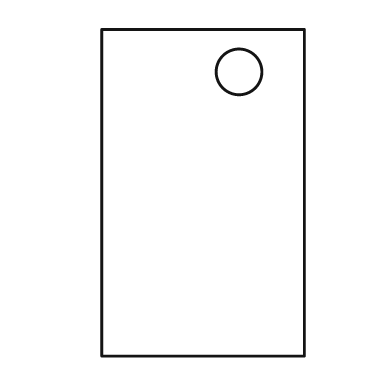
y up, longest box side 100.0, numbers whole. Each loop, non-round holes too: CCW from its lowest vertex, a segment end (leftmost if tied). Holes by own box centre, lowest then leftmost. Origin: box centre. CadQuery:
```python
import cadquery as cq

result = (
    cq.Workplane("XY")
    .moveTo(-31.0, -50.0)
    .lineTo(31.0, -50.0)
    .lineTo(31.0, 50.0)
    .lineTo(-31.0, 50.0)
    .close()
    .moveTo(11.0, 37.0)
    .circle(7.0)
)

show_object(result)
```